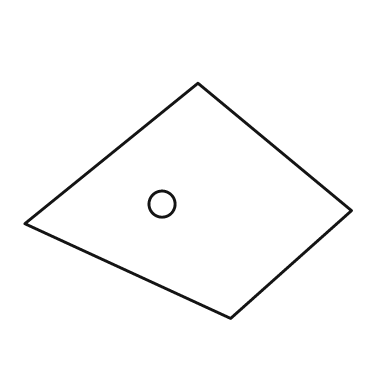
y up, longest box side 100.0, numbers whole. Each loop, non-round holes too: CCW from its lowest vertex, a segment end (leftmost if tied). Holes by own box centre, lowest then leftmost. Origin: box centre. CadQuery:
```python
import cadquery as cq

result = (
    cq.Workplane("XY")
    .moveTo(13.0, -36.0)
    .lineTo(50.0, -3.0)
    .lineTo(3.0, 36.0)
    .lineTo(-50.0, -7.0)
    .close()
    .moveTo(-8.0, -1.0)
    .circle(4.0)
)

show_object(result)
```